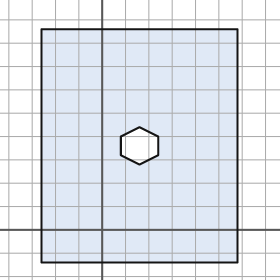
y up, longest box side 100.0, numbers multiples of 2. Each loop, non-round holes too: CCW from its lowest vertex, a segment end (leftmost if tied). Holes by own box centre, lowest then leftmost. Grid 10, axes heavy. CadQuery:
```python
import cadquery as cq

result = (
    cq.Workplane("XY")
    .moveTo(-26.0, -14.0)
    .lineTo(58.0, -14.0)
    .lineTo(58.0, 86.0)
    .lineTo(-26.0, 86.0)
    .close()
    .moveTo(16.0, 28.0)
    .lineTo(24.0, 32.0)
    .lineTo(24.0, 40.0)
    .lineTo(16.0, 44.0)
    .lineTo(8.0, 40.0)
    .lineTo(8.0, 32.0)
    .close()
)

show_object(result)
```